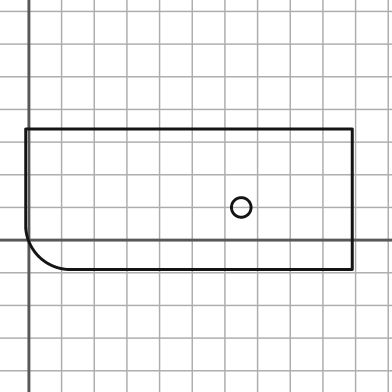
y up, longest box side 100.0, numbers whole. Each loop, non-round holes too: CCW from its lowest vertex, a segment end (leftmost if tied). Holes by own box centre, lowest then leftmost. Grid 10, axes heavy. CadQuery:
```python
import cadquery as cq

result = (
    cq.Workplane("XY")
    .moveTo(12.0, -9.0)
    .lineTo(99.0, -9.0)
    .lineTo(99.0, 34.0)
    .lineTo(-1.0, 34.0)
    .lineTo(-1.0, 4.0)
    .threePointArc((3.0, -5.0), (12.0, -9.0))
    .close()
    .moveTo(65.0, 10.0)
    .circle(3.0)
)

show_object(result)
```